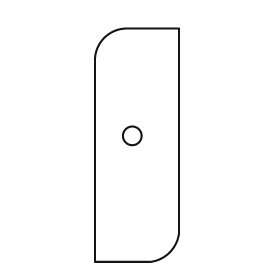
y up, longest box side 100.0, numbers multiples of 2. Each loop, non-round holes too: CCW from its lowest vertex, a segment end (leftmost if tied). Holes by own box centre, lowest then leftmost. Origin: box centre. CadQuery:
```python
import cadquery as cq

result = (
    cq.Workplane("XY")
    .moveTo(-18.0, -50.0)
    .lineTo(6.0, -50.0)
    .threePointArc((14.0, -46.0), (18.0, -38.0))
    .lineTo(18.0, 50.0)
    .lineTo(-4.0, 50.0)
    .threePointArc((-14.0, 46.0), (-18.0, 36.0))
    .close()
    .moveTo(-2.0, 4.0)
    .circle(4.0)
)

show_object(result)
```